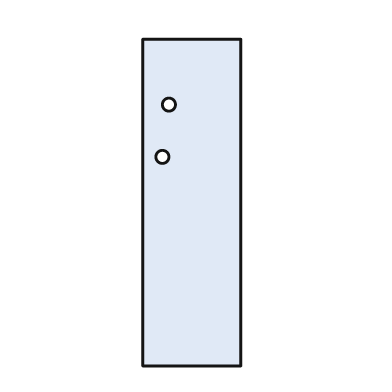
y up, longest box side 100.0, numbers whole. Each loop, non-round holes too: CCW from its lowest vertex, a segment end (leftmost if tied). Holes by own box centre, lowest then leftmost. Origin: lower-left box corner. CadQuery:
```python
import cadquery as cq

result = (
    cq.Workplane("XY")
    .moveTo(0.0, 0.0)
    .lineTo(30.0, 0.0)
    .lineTo(30.0, 100.0)
    .lineTo(0.0, 100.0)
    .close()
    .moveTo(6.0, 64.0)
    .circle(2.0)
    .moveTo(8.0, 80.0)
    .circle(2.0)
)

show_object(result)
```